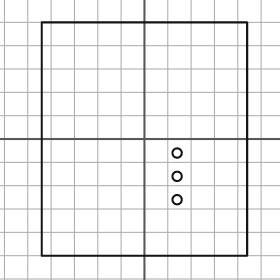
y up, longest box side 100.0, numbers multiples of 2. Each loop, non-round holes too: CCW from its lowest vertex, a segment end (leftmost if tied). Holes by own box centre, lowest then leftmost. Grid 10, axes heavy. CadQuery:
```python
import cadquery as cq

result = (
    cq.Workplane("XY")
    .moveTo(-44.0, -50.0)
    .lineTo(44.0, -50.0)
    .lineTo(44.0, 50.0)
    .lineTo(-44.0, 50.0)
    .close()
    .moveTo(14.0, -26.0)
    .circle(2.0)
    .moveTo(14.0, -16.0)
    .circle(2.0)
    .moveTo(14.0, -6.0)
    .circle(2.0)
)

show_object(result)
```